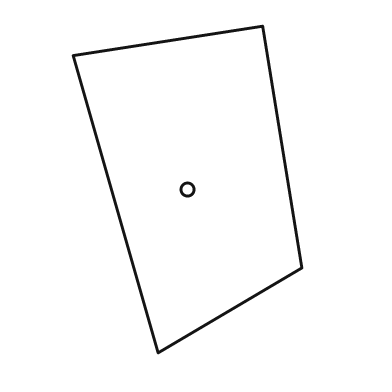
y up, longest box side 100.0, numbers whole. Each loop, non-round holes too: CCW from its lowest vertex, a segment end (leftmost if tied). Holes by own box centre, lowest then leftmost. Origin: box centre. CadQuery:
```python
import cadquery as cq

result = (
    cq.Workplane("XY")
    .moveTo(-9.0, -50.0)
    .lineTo(35.0, -24.0)
    .lineTo(23.0, 50.0)
    .lineTo(-35.0, 41.0)
    .close()
    .moveTo(0.0, 0.0)
    .circle(2.0)
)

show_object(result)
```